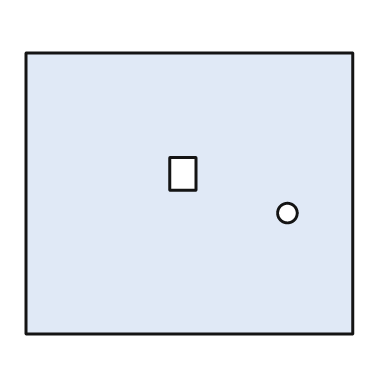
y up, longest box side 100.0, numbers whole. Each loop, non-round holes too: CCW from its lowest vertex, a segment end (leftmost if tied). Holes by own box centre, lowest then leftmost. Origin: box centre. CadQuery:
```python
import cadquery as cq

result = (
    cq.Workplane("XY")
    .moveTo(-50.0, -43.0)
    .lineTo(50.0, -43.0)
    .lineTo(50.0, 43.0)
    .lineTo(-50.0, 43.0)
    .close()
    .moveTo(30.0, -6.0)
    .circle(3.0)
    .moveTo(-6.0, 1.0)
    .lineTo(2.0, 1.0)
    .lineTo(2.0, 11.0)
    .lineTo(-6.0, 11.0)
    .close()
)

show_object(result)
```